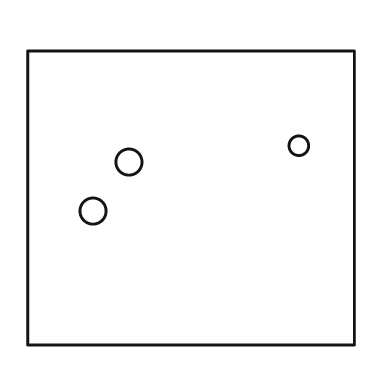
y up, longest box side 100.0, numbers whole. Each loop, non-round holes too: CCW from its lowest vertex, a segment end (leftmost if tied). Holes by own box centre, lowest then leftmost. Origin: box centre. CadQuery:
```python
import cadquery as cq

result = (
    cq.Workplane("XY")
    .moveTo(-50.0, -45.0)
    .lineTo(50.0, -45.0)
    .lineTo(50.0, 45.0)
    .lineTo(-50.0, 45.0)
    .close()
    .moveTo(-30.0, -4.0)
    .circle(4.0)
    .moveTo(-19.0, 11.0)
    .circle(4.0)
    .moveTo(33.0, 16.0)
    .circle(3.0)
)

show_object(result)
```